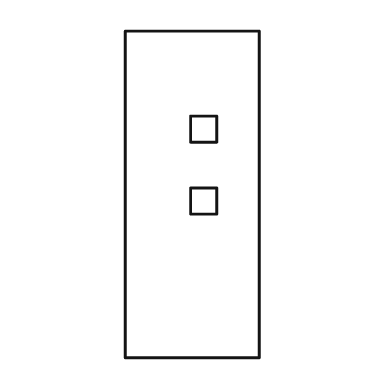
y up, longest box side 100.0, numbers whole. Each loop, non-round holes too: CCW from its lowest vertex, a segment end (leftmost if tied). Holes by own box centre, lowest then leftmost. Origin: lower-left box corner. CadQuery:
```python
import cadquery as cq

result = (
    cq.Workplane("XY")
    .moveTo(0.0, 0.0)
    .lineTo(41.0, 0.0)
    .lineTo(41.0, 100.0)
    .lineTo(0.0, 100.0)
    .close()
    .moveTo(20.0, 44.0)
    .lineTo(28.0, 44.0)
    .lineTo(28.0, 52.0)
    .lineTo(20.0, 52.0)
    .close()
    .moveTo(20.0, 66.0)
    .lineTo(28.0, 66.0)
    .lineTo(28.0, 74.0)
    .lineTo(20.0, 74.0)
    .close()
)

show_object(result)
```